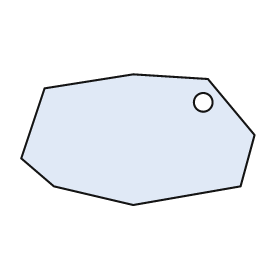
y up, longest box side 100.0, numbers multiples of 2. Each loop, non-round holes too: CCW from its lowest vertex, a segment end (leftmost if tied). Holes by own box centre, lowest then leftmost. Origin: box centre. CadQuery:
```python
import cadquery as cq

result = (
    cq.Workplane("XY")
    .moveTo(-2.0, -28.0)
    .lineTo(44.0, -20.0)
    .lineTo(50.0, 2.0)
    .lineTo(30.0, 26.0)
    .lineTo(-2.0, 28.0)
    .lineTo(-40.0, 22.0)
    .lineTo(-50.0, -8.0)
    .lineTo(-36.0, -20.0)
    .close()
    .moveTo(28.0, 16.0)
    .circle(4.0)
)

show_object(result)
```